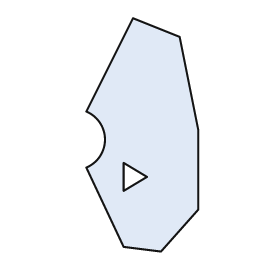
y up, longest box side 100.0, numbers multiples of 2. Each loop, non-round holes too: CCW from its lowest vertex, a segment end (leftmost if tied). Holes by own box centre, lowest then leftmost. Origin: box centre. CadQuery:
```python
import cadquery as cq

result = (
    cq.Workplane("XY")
    .moveTo(8.0, -50.0)
    .lineTo(24.0, -32.0)
    .lineTo(24.0, 2.0)
    .lineTo(16.0, 42.0)
    .lineTo(-4.0, 50.0)
    .lineTo(-24.0, 10.0)
    .threePointArc((-16.0, -2.0), (-24.0, -14.0))
    .lineTo(-8.0, -48.0)
    .close()
    .moveTo(-8.0, -24.0)
    .lineTo(2.0, -18.0)
    .lineTo(-8.0, -12.0)
    .close()
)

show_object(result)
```